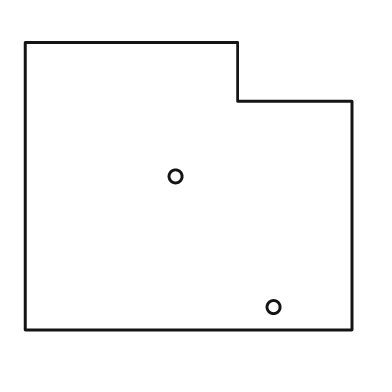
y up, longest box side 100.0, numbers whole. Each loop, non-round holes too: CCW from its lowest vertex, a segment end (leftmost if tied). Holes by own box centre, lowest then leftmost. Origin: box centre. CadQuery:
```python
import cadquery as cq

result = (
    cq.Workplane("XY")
    .moveTo(-50.0, -44.0)
    .lineTo(50.0, -44.0)
    .lineTo(50.0, 26.0)
    .lineTo(15.0, 26.0)
    .lineTo(15.0, 44.0)
    .lineTo(-50.0, 44.0)
    .close()
    .moveTo(26.0, -37.0)
    .circle(2.0)
    .moveTo(-4.0, 3.0)
    .circle(2.0)
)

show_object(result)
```